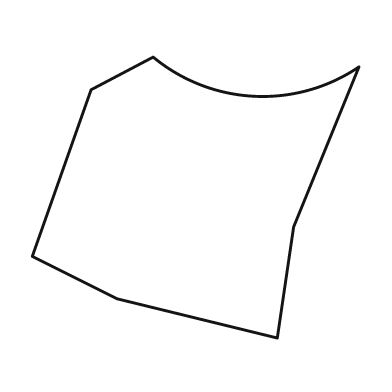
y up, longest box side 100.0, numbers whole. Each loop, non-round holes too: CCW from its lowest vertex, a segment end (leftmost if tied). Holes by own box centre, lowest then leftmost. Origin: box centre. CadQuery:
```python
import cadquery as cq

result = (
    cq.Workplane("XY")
    .moveTo(25.0, -43.0)
    .lineTo(30.0, -9.0)
    .lineTo(50.0, 40.0)
    .threePointArc((18.0, 31.0), (-13.0, 43.0))
    .lineTo(-32.0, 33.0)
    .lineTo(-50.0, -18.0)
    .lineTo(-24.0, -31.0)
    .close()
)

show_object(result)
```